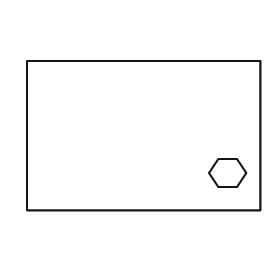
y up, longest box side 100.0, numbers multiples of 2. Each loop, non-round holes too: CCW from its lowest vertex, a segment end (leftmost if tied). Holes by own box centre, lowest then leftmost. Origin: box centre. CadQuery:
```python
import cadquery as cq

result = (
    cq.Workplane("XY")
    .moveTo(-50.0, -32.0)
    .lineTo(50.0, -32.0)
    .lineTo(50.0, 32.0)
    .lineTo(-50.0, 32.0)
    .close()
    .moveTo(32.0, -22.0)
    .lineTo(40.0, -22.0)
    .lineTo(44.0, -16.0)
    .lineTo(40.0, -10.0)
    .lineTo(32.0, -10.0)
    .lineTo(28.0, -16.0)
    .close()
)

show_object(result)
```